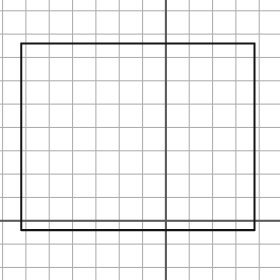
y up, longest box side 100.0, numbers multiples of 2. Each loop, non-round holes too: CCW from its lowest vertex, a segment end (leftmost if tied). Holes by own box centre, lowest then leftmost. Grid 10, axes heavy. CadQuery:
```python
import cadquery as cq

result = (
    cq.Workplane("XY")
    .moveTo(-62.0, -4.0)
    .lineTo(38.0, -4.0)
    .lineTo(38.0, 76.0)
    .lineTo(-62.0, 76.0)
    .close()
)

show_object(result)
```